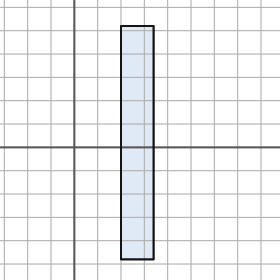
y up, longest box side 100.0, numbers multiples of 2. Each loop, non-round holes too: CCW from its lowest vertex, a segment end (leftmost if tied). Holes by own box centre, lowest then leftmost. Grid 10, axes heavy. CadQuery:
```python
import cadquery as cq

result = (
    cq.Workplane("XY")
    .moveTo(20.0, -48.0)
    .lineTo(34.0, -48.0)
    .lineTo(34.0, 52.0)
    .lineTo(20.0, 52.0)
    .close()
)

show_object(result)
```